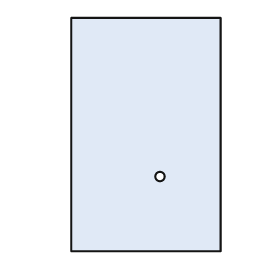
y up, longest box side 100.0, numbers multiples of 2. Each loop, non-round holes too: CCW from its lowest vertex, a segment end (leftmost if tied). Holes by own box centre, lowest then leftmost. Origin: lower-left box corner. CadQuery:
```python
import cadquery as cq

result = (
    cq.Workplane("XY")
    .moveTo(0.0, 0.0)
    .lineTo(64.0, 0.0)
    .lineTo(64.0, 100.0)
    .lineTo(0.0, 100.0)
    .close()
    .moveTo(38.0, 32.0)
    .circle(2.0)
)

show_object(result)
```